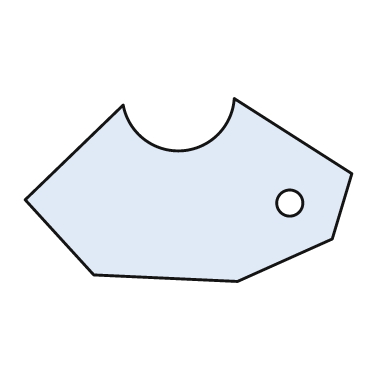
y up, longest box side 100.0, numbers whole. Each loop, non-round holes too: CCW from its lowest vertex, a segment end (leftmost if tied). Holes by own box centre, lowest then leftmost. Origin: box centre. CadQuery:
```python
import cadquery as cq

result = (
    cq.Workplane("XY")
    .moveTo(15.0, -28.0)
    .lineTo(44.0, -15.0)
    .lineTo(50.0, 5.0)
    .lineTo(14.0, 28.0)
    .threePointArc((-2.0, 12.0), (-20.0, 26.0))
    .lineTo(-50.0, -3.0)
    .lineTo(-29.0, -26.0)
    .close()
    .moveTo(31.0, -4.0)
    .circle(4.0)
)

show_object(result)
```